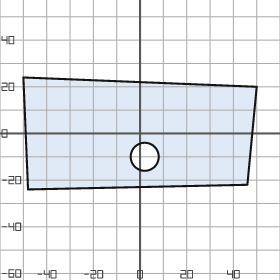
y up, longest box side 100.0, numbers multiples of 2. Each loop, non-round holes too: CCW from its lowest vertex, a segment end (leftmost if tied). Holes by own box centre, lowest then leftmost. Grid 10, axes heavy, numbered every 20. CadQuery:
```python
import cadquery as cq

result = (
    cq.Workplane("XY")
    .moveTo(-48.0, -24.0)
    .lineTo(46.0, -22.0)
    .lineTo(50.0, 20.0)
    .lineTo(-50.0, 24.0)
    .close()
    .moveTo(2.0, -10.0)
    .circle(6.0)
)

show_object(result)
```